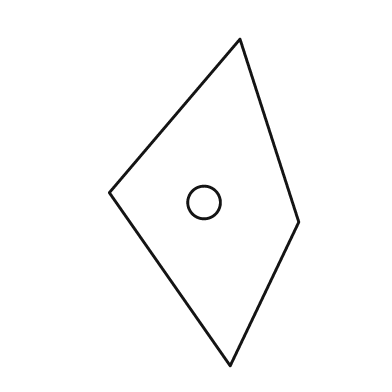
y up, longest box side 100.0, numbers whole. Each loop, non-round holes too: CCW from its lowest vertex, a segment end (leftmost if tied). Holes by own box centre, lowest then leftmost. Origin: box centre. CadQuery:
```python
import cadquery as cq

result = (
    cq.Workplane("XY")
    .moveTo(8.0, -50.0)
    .lineTo(29.0, -6.0)
    .lineTo(11.0, 50.0)
    .lineTo(-29.0, 3.0)
    .close()
    .moveTo(0.0, 0.0)
    .circle(5.0)
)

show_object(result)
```